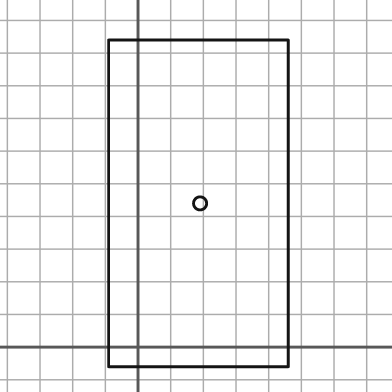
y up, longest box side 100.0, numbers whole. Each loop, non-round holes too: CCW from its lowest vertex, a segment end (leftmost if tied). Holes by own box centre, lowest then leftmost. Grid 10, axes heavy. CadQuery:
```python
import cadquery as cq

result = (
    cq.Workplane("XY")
    .moveTo(-9.0, -6.0)
    .lineTo(46.0, -6.0)
    .lineTo(46.0, 94.0)
    .lineTo(-9.0, 94.0)
    .close()
    .moveTo(19.0, 44.0)
    .circle(2.0)
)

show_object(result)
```